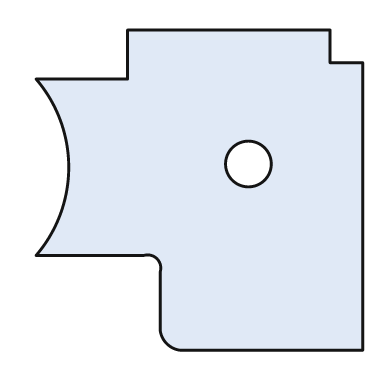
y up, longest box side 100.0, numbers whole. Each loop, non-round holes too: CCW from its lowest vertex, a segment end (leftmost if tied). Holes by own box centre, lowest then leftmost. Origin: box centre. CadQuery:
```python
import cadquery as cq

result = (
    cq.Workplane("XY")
    .moveTo(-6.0, -49.0)
    .lineTo(50.0, -49.0)
    .lineTo(50.0, 39.0)
    .lineTo(40.0, 39.0)
    .lineTo(40.0, 49.0)
    .lineTo(-22.0, 49.0)
    .lineTo(-22.0, 34.0)
    .lineTo(-50.0, 34.0)
    .threePointArc((-40.0, 7.0), (-50.0, -20.0))
    .lineTo(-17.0, -20.0)
    .threePointArc((-13.0, -21.0), (-12.0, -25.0))
    .lineTo(-12.0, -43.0)
    .threePointArc((-10.0, -47.0), (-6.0, -49.0))
    .close()
    .moveTo(15.0, 8.0)
    .circle(7.0)
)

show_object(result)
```